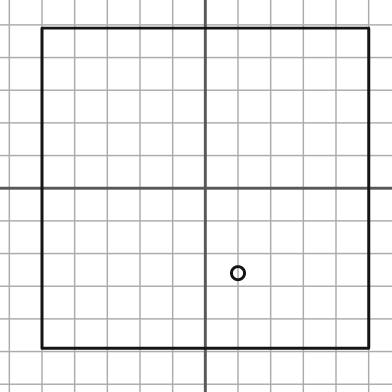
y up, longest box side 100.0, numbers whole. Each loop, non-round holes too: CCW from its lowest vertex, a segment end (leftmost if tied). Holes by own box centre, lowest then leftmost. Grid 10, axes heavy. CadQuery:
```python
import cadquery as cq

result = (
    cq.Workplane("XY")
    .moveTo(-50.0, -49.0)
    .lineTo(50.0, -49.0)
    .lineTo(50.0, 49.0)
    .lineTo(-50.0, 49.0)
    .close()
    .moveTo(10.0, -26.0)
    .circle(2.0)
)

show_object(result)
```